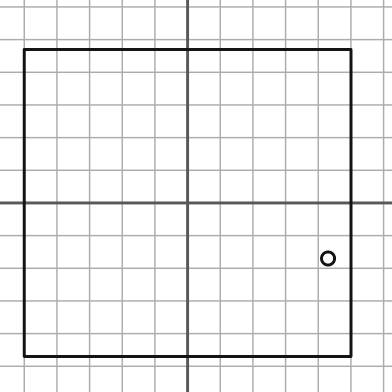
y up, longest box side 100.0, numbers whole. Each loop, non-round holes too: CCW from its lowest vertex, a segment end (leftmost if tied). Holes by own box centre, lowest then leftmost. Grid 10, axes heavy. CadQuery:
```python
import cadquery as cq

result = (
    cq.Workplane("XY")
    .moveTo(-50.0, -47.0)
    .lineTo(50.0, -47.0)
    .lineTo(50.0, 47.0)
    .lineTo(-50.0, 47.0)
    .close()
    .moveTo(43.0, -17.0)
    .circle(2.0)
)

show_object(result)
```